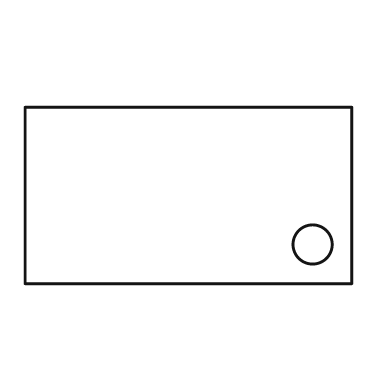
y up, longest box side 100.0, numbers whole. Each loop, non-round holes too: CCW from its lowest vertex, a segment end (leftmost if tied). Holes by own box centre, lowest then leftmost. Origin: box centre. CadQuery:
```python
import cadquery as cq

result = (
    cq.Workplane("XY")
    .moveTo(-50.0, -27.0)
    .lineTo(50.0, -27.0)
    .lineTo(50.0, 27.0)
    .lineTo(-50.0, 27.0)
    .close()
    .moveTo(38.0, -15.0)
    .circle(6.0)
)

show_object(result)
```